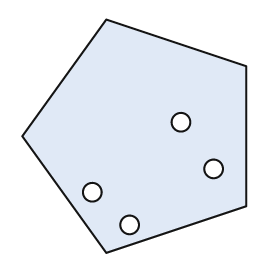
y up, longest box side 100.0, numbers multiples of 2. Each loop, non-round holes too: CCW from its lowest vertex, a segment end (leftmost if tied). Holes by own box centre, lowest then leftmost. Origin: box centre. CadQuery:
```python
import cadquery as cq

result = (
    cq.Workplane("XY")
    .moveTo(-12.0, -50.0)
    .lineTo(48.0, -30.0)
    .lineTo(48.0, 30.0)
    .lineTo(-12.0, 50.0)
    .lineTo(-48.0, 0.0)
    .close()
    .moveTo(-2.0, -38.0)
    .circle(4.0)
    .moveTo(-18.0, -24.0)
    .circle(4.0)
    .moveTo(34.0, -14.0)
    .circle(4.0)
    .moveTo(20.0, 6.0)
    .circle(4.0)
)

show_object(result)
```